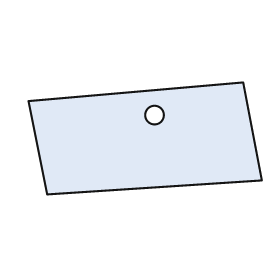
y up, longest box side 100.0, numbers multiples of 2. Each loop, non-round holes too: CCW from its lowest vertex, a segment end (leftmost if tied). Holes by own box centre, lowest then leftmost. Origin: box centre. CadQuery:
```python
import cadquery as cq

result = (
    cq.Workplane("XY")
    .moveTo(-42.0, -24.0)
    .lineTo(50.0, -18.0)
    .lineTo(42.0, 24.0)
    .lineTo(-50.0, 16.0)
    .close()
    .moveTo(4.0, 10.0)
    .circle(4.0)
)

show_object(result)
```